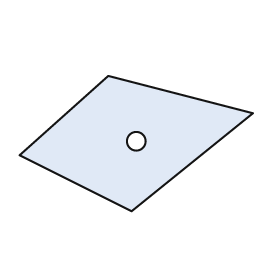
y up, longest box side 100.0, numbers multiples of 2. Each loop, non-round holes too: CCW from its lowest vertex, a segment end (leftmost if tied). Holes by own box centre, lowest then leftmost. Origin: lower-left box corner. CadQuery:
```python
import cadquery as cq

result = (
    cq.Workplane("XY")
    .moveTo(48.0, 0.0)
    .lineTo(100.0, 42.0)
    .lineTo(38.0, 58.0)
    .lineTo(0.0, 24.0)
    .close()
    .moveTo(50.0, 30.0)
    .circle(4.0)
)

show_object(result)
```